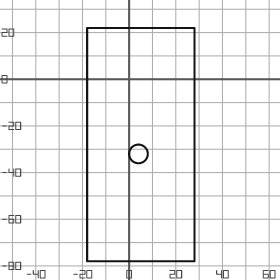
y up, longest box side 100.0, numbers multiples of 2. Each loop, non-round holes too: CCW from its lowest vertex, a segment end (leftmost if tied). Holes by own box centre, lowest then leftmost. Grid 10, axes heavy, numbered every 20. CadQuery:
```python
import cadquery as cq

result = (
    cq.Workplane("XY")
    .moveTo(-18.0, -78.0)
    .lineTo(28.0, -78.0)
    .lineTo(28.0, 22.0)
    .lineTo(-18.0, 22.0)
    .close()
    .moveTo(4.0, -32.0)
    .circle(4.0)
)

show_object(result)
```